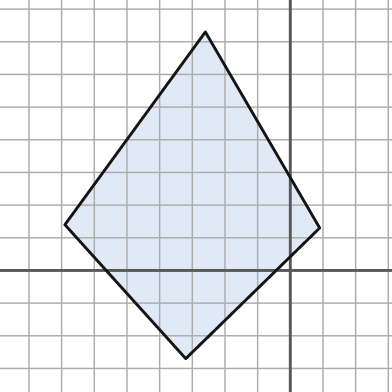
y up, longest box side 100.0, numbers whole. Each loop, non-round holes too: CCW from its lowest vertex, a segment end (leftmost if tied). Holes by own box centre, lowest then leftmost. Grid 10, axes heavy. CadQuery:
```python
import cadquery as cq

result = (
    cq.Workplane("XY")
    .moveTo(-32.0, -27.0)
    .lineTo(9.0, 13.0)
    .lineTo(-26.0, 73.0)
    .lineTo(-69.0, 14.0)
    .close()
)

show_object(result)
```